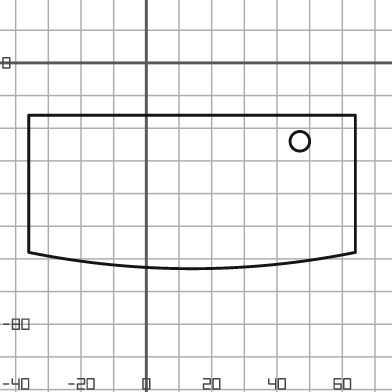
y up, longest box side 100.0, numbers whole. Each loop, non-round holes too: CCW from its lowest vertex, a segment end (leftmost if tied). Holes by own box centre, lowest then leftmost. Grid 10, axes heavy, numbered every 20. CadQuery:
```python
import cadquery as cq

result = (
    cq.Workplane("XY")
    .moveTo(-36.0, -58.0)
    .threePointArc((14.0, -63.0), (64.0, -58.0))
    .lineTo(64.0, -16.0)
    .lineTo(-36.0, -16.0)
    .close()
    .moveTo(47.0, -24.0)
    .circle(3.0)
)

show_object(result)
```